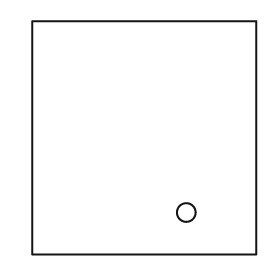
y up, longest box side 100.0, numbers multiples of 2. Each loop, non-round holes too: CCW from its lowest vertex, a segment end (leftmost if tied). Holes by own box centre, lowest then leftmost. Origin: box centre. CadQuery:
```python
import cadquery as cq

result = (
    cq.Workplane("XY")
    .moveTo(-48.0, -50.0)
    .lineTo(48.0, -50.0)
    .lineTo(48.0, 50.0)
    .lineTo(-48.0, 50.0)
    .close()
    .moveTo(18.0, -32.0)
    .circle(4.0)
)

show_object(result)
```